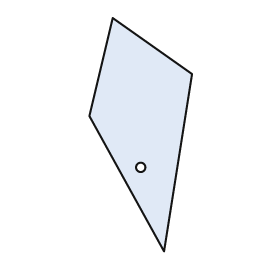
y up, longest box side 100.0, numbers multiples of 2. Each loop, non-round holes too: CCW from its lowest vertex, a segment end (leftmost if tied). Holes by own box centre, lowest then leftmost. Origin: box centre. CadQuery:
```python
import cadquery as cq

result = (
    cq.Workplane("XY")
    .moveTo(10.0, -50.0)
    .lineTo(22.0, 26.0)
    .lineTo(-12.0, 50.0)
    .lineTo(-22.0, 8.0)
    .close()
    .moveTo(0.0, -14.0)
    .circle(2.0)
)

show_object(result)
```